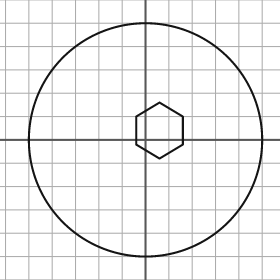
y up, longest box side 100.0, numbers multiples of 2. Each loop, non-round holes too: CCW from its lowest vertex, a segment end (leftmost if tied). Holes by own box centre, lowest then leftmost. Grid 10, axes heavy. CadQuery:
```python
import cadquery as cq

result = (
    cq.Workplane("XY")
    .moveTo(0.0, 0.0)
    .circle(50.0)
    .moveTo(6.0, -8.0)
    .lineTo(16.0, -2.0)
    .lineTo(16.0, 10.0)
    .lineTo(6.0, 16.0)
    .lineTo(-4.0, 10.0)
    .lineTo(-4.0, -2.0)
    .close()
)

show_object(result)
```